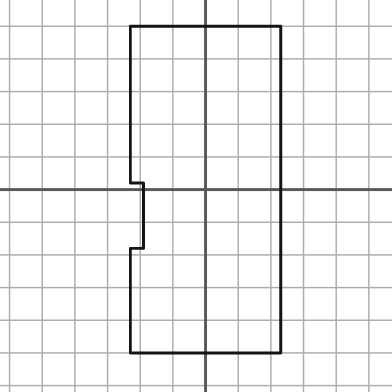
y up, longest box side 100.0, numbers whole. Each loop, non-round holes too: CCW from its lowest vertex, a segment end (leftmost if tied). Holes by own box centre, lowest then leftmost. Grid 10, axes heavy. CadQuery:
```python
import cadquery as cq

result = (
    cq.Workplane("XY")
    .moveTo(-23.0, -50.0)
    .lineTo(23.0, -50.0)
    .lineTo(23.0, 50.0)
    .lineTo(-23.0, 50.0)
    .lineTo(-23.0, 2.0)
    .lineTo(-19.0, 2.0)
    .lineTo(-19.0, -18.0)
    .lineTo(-23.0, -18.0)
    .close()
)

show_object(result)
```